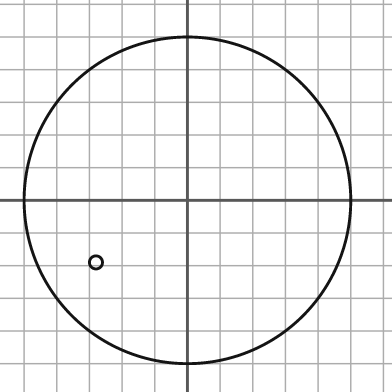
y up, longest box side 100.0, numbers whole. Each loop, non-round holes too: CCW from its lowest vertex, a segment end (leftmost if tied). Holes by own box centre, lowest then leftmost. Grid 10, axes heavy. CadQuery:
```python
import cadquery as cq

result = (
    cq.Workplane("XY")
    .moveTo(0.0, 0.0)
    .circle(50.0)
    .moveTo(-28.0, -19.0)
    .circle(2.0)
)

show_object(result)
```